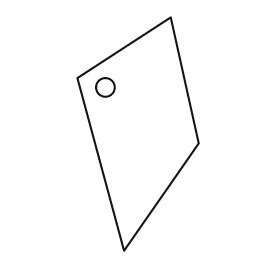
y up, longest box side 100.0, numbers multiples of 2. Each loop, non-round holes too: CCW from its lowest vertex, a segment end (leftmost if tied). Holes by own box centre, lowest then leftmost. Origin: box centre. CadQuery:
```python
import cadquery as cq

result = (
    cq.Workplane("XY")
    .moveTo(-6.0, -50.0)
    .lineTo(26.0, -4.0)
    .lineTo(14.0, 50.0)
    .lineTo(-26.0, 24.0)
    .close()
    .moveTo(-14.0, 20.0)
    .circle(4.0)
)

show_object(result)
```